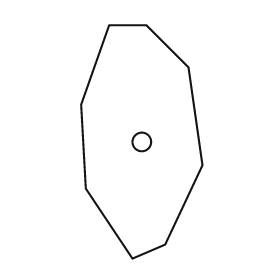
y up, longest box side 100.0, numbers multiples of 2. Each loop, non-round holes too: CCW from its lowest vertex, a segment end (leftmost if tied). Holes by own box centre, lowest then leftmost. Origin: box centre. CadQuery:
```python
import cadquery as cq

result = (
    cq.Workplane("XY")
    .moveTo(-4.0, -50.0)
    .lineTo(10.0, -44.0)
    .lineTo(26.0, -10.0)
    .lineTo(20.0, 32.0)
    .lineTo(2.0, 50.0)
    .lineTo(-14.0, 50.0)
    .lineTo(-26.0, 16.0)
    .lineTo(-24.0, -20.0)
    .close()
    .moveTo(0.0, 0.0)
    .circle(4.0)
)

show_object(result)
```